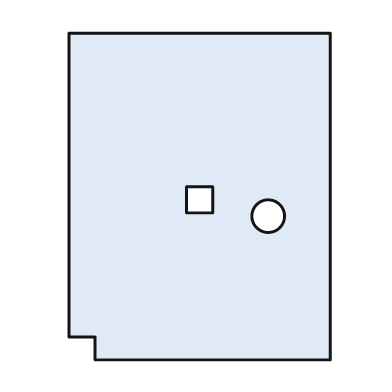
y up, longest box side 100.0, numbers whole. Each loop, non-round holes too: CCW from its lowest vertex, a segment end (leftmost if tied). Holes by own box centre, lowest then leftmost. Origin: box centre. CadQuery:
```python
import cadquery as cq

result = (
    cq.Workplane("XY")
    .moveTo(-32.0, -50.0)
    .lineTo(40.0, -50.0)
    .lineTo(40.0, 50.0)
    .lineTo(-40.0, 50.0)
    .lineTo(-40.0, -43.0)
    .lineTo(-32.0, -43.0)
    .close()
    .moveTo(21.0, -6.0)
    .circle(5.0)
    .moveTo(-4.0, -5.0)
    .lineTo(4.0, -5.0)
    .lineTo(4.0, 3.0)
    .lineTo(-4.0, 3.0)
    .close()
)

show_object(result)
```